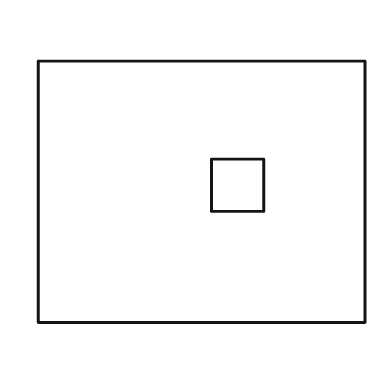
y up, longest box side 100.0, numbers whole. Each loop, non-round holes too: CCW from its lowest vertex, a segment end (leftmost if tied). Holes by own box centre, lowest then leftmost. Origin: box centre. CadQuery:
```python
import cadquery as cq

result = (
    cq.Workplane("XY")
    .moveTo(-50.0, -40.0)
    .lineTo(50.0, -40.0)
    .lineTo(50.0, 40.0)
    .lineTo(-50.0, 40.0)
    .close()
    .moveTo(3.0, -6.0)
    .lineTo(19.0, -6.0)
    .lineTo(19.0, 10.0)
    .lineTo(3.0, 10.0)
    .close()
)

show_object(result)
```